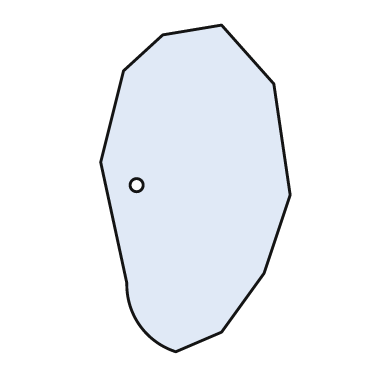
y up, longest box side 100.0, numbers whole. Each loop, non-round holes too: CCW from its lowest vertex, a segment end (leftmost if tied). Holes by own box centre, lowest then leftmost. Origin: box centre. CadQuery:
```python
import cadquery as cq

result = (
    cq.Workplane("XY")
    .moveTo(-6.0, -50.0)
    .lineTo(8.0, -44.0)
    .lineTo(21.0, -26.0)
    .lineTo(29.0, -2.0)
    .lineTo(24.0, 32.0)
    .lineTo(8.0, 50.0)
    .lineTo(-10.0, 47.0)
    .lineTo(-22.0, 36.0)
    .lineTo(-29.0, 8.0)
    .lineTo(-21.0, -29.0)
    .threePointArc((-17.0, -42.0), (-6.0, -50.0))
    .close()
    .moveTo(-18.0, 1.0)
    .circle(2.0)
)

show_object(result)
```